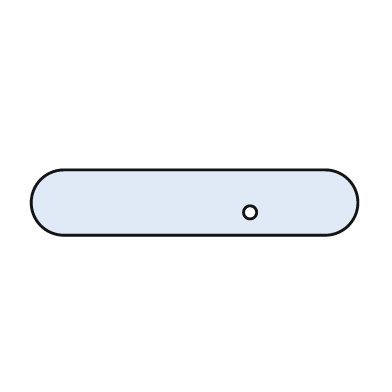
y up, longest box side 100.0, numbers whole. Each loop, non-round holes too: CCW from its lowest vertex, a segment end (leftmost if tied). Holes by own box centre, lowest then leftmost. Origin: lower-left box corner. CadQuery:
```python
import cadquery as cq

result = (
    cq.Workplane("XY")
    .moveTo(10.0, 0.0)
    .lineTo(90.0, 0.0)
    .threePointArc((100.0, 10.0), (90.0, 20.0))
    .lineTo(10.0, 20.0)
    .threePointArc((0.0, 10.0), (10.0, 0.0))
    .close()
    .moveTo(67.0, 7.0)
    .circle(2.0)
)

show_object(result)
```